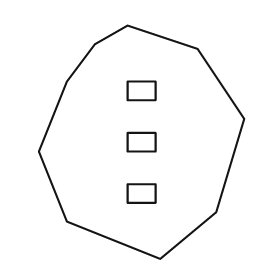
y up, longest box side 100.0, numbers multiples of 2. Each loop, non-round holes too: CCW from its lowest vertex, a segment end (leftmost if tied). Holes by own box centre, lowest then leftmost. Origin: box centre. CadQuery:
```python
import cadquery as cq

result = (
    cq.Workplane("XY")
    .moveTo(8.0, -50.0)
    .lineTo(32.0, -30.0)
    .lineTo(44.0, 10.0)
    .lineTo(24.0, 40.0)
    .lineTo(-6.0, 50.0)
    .lineTo(-20.0, 42.0)
    .lineTo(-32.0, 26.0)
    .lineTo(-44.0, -4.0)
    .lineTo(-32.0, -34.0)
    .close()
    .moveTo(-6.0, -26.0)
    .lineTo(6.0, -26.0)
    .lineTo(6.0, -18.0)
    .lineTo(-6.0, -18.0)
    .close()
    .moveTo(-6.0, -4.0)
    .lineTo(6.0, -4.0)
    .lineTo(6.0, 4.0)
    .lineTo(-6.0, 4.0)
    .close()
    .moveTo(-6.0, 18.0)
    .lineTo(6.0, 18.0)
    .lineTo(6.0, 26.0)
    .lineTo(-6.0, 26.0)
    .close()
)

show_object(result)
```